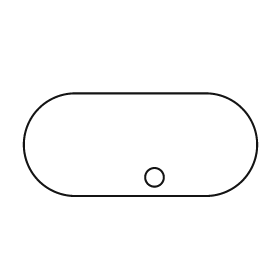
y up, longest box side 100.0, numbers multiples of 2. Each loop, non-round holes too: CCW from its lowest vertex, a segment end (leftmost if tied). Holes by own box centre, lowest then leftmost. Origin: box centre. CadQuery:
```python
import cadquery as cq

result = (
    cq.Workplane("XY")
    .moveTo(-28.0, -22.0)
    .lineTo(28.0, -22.0)
    .threePointArc((50.0, 0.0), (28.0, 22.0))
    .lineTo(-28.0, 22.0)
    .threePointArc((-50.0, 0.0), (-28.0, -22.0))
    .close()
    .moveTo(6.0, -14.0)
    .circle(4.0)
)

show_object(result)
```